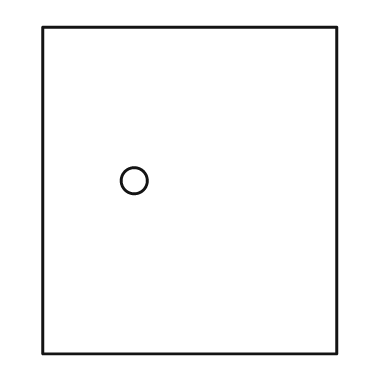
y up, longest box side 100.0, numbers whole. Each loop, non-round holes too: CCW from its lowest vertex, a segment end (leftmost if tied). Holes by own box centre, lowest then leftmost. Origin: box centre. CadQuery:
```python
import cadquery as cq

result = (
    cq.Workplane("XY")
    .moveTo(-45.0, -50.0)
    .lineTo(45.0, -50.0)
    .lineTo(45.0, 50.0)
    .lineTo(-45.0, 50.0)
    .close()
    .moveTo(-17.0, 3.0)
    .circle(4.0)
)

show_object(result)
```